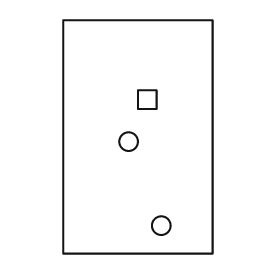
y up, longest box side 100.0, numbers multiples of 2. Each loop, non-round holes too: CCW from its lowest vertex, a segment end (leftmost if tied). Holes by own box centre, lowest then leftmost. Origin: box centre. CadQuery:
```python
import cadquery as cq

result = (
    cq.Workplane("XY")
    .moveTo(-32.0, -50.0)
    .lineTo(32.0, -50.0)
    .lineTo(32.0, 50.0)
    .lineTo(-32.0, 50.0)
    .close()
    .moveTo(10.0, -38.0)
    .circle(4.0)
    .moveTo(-4.0, -2.0)
    .circle(4.0)
    .moveTo(0.0, 12.0)
    .lineTo(8.0, 12.0)
    .lineTo(8.0, 20.0)
    .lineTo(0.0, 20.0)
    .close()
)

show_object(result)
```